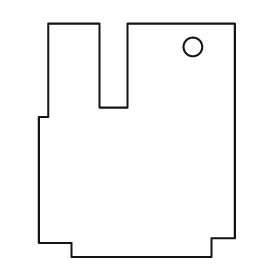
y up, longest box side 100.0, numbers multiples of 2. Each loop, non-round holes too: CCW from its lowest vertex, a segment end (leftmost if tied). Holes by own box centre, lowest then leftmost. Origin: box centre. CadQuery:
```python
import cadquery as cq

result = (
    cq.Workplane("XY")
    .moveTo(-28.0, -50.0)
    .lineTo(32.0, -50.0)
    .lineTo(32.0, -42.0)
    .lineTo(42.0, -42.0)
    .lineTo(42.0, 50.0)
    .lineTo(-4.0, 50.0)
    .lineTo(-4.0, 14.0)
    .lineTo(-16.0, 14.0)
    .lineTo(-16.0, 50.0)
    .lineTo(-38.0, 50.0)
    .lineTo(-38.0, 10.0)
    .lineTo(-42.0, 10.0)
    .lineTo(-42.0, -44.0)
    .lineTo(-28.0, -44.0)
    .close()
    .moveTo(24.0, 40.0)
    .circle(4.0)
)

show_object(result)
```